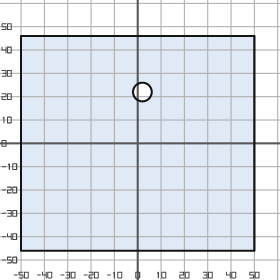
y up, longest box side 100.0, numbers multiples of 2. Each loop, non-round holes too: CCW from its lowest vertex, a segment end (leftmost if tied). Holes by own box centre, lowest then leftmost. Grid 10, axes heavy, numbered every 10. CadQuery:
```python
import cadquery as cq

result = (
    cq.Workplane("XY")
    .moveTo(-50.0, -46.0)
    .lineTo(50.0, -46.0)
    .lineTo(50.0, 46.0)
    .lineTo(-50.0, 46.0)
    .close()
    .moveTo(2.0, 22.0)
    .circle(4.0)
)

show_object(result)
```